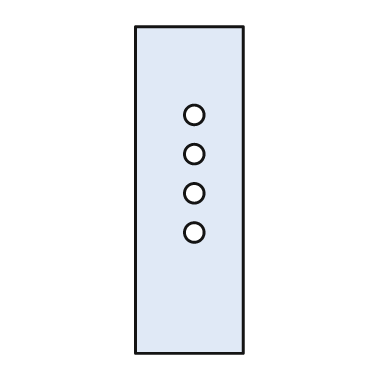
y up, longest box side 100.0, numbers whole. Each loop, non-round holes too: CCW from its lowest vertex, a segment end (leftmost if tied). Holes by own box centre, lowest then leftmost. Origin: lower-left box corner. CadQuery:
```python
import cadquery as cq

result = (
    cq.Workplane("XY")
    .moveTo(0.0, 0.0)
    .lineTo(33.0, 0.0)
    .lineTo(33.0, 100.0)
    .lineTo(0.0, 100.0)
    .close()
    .moveTo(18.0, 37.0)
    .circle(3.0)
    .moveTo(18.0, 49.0)
    .circle(3.0)
    .moveTo(18.0, 61.0)
    .circle(3.0)
    .moveTo(18.0, 73.0)
    .circle(3.0)
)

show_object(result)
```